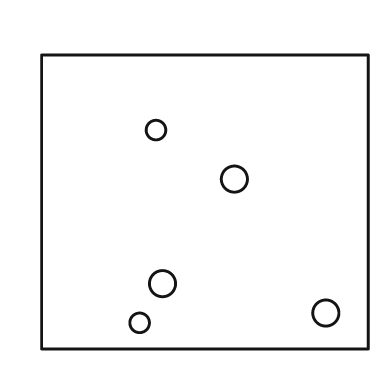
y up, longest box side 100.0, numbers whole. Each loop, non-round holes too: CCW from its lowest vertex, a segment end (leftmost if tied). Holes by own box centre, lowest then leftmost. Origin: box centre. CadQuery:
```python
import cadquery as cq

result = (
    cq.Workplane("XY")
    .moveTo(-50.0, -45.0)
    .lineTo(50.0, -45.0)
    .lineTo(50.0, 45.0)
    .lineTo(-50.0, 45.0)
    .close()
    .moveTo(-20.0, -37.0)
    .circle(3.0)
    .moveTo(37.0, -34.0)
    .circle(4.0)
    .moveTo(-13.0, -25.0)
    .circle(4.0)
    .moveTo(9.0, 7.0)
    .circle(4.0)
    .moveTo(-15.0, 22.0)
    .circle(3.0)
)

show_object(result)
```